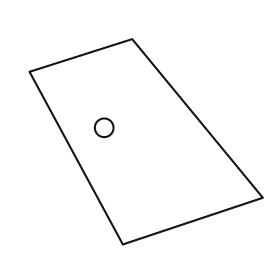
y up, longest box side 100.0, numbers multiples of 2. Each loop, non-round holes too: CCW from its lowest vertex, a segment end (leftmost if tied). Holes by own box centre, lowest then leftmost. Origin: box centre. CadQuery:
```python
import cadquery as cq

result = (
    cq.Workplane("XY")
    .moveTo(-10.0, -44.0)
    .lineTo(50.0, -24.0)
    .lineTo(-6.0, 44.0)
    .lineTo(-50.0, 30.0)
    .close()
    .moveTo(-18.0, 6.0)
    .circle(4.0)
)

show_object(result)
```